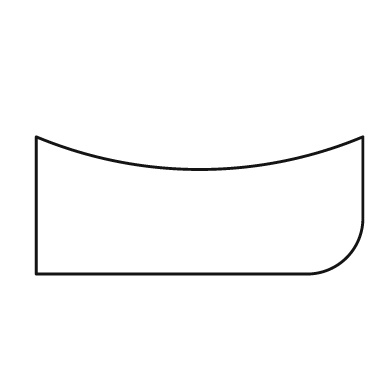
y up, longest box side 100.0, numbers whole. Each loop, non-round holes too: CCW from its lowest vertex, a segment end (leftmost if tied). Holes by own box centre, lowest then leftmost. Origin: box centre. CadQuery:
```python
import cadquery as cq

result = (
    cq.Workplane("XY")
    .moveTo(-50.0, -21.0)
    .lineTo(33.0, -21.0)
    .threePointArc((45.0, -16.0), (50.0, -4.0))
    .lineTo(50.0, 21.0)
    .threePointArc((0.0, 11.0), (-50.0, 21.0))
    .close()
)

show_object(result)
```